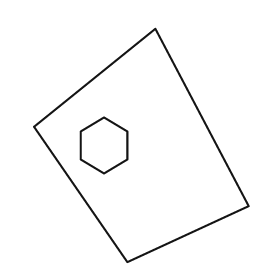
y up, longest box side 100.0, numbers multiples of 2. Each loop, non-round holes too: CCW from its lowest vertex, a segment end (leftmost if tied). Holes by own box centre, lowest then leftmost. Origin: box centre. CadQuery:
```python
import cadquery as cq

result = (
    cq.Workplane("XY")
    .moveTo(-6.0, -50.0)
    .lineTo(46.0, -26.0)
    .lineTo(6.0, 50.0)
    .lineTo(-46.0, 8.0)
    .close()
    .moveTo(-16.0, -12.0)
    .lineTo(-6.0, -6.0)
    .lineTo(-6.0, 6.0)
    .lineTo(-16.0, 12.0)
    .lineTo(-26.0, 6.0)
    .lineTo(-26.0, -6.0)
    .close()
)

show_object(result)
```